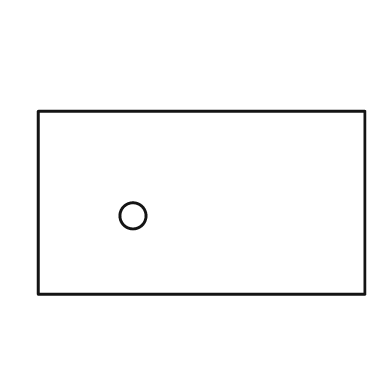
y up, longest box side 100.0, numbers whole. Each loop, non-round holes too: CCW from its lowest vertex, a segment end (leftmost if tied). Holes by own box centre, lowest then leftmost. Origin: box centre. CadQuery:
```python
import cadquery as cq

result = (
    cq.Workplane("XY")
    .moveTo(-50.0, -28.0)
    .lineTo(50.0, -28.0)
    .lineTo(50.0, 28.0)
    .lineTo(-50.0, 28.0)
    .close()
    .moveTo(-21.0, -4.0)
    .circle(4.0)
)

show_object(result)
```